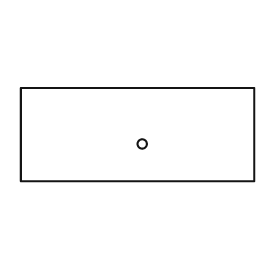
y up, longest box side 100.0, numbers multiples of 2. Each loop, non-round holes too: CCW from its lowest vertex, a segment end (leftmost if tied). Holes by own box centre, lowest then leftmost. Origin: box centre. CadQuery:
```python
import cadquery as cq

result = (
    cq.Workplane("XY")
    .moveTo(-50.0, -20.0)
    .lineTo(50.0, -20.0)
    .lineTo(50.0, 20.0)
    .lineTo(-50.0, 20.0)
    .close()
    .moveTo(2.0, -4.0)
    .circle(2.0)
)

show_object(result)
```